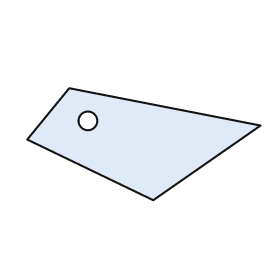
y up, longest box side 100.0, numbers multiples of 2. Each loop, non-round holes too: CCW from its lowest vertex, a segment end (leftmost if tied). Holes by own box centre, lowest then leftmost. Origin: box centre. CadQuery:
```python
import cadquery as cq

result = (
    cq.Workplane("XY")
    .moveTo(4.0, -24.0)
    .lineTo(50.0, 8.0)
    .lineTo(-32.0, 24.0)
    .lineTo(-50.0, 2.0)
    .close()
    .moveTo(-24.0, 10.0)
    .circle(4.0)
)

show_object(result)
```